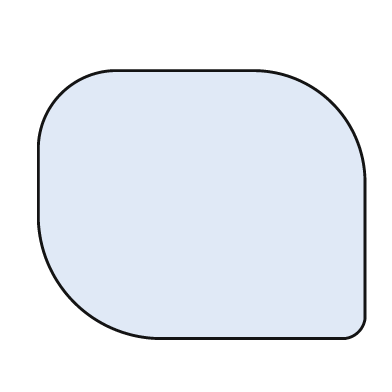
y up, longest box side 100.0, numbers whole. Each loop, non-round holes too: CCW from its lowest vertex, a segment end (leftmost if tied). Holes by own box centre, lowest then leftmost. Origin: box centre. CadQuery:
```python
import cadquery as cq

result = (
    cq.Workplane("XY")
    .moveTo(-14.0, -41.0)
    .lineTo(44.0, -41.0)
    .threePointArc((48.0, -39.0), (50.0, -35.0))
    .lineTo(50.0, 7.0)
    .threePointArc((40.0, 31.0), (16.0, 41.0))
    .lineTo(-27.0, 41.0)
    .threePointArc((-43.0, 34.0), (-50.0, 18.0))
    .lineTo(-50.0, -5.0)
    .threePointArc((-39.0, -30.0), (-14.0, -41.0))
    .close()
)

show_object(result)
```